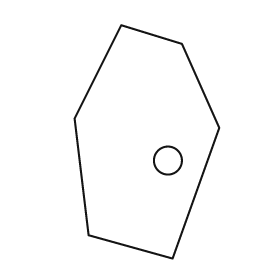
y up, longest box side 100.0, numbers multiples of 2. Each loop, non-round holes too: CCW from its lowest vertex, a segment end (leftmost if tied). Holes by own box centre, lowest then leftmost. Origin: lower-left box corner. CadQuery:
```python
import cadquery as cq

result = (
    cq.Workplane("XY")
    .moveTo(42.0, 0.0)
    .lineTo(62.0, 56.0)
    .lineTo(46.0, 92.0)
    .lineTo(20.0, 100.0)
    .lineTo(0.0, 60.0)
    .lineTo(6.0, 10.0)
    .close()
    .moveTo(40.0, 42.0)
    .circle(6.0)
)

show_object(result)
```